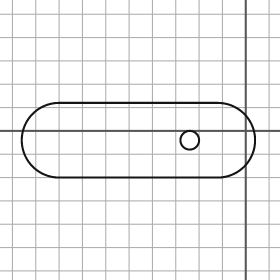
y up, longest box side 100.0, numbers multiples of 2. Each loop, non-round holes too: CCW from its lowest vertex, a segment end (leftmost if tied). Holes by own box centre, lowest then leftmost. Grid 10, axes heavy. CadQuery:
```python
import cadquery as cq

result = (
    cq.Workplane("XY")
    .moveTo(-80.0, -20.0)
    .lineTo(-12.0, -20.0)
    .threePointArc((4.0, -4.0), (-12.0, 12.0))
    .lineTo(-80.0, 12.0)
    .threePointArc((-96.0, -4.0), (-80.0, -20.0))
    .close()
    .moveTo(-24.0, -4.0)
    .circle(4.0)
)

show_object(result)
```